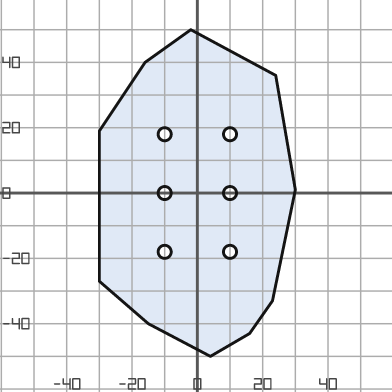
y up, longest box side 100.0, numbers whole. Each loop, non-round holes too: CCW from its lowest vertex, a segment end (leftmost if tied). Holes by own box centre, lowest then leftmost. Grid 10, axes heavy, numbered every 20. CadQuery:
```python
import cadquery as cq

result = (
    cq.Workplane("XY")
    .moveTo(4.0, -50.0)
    .lineTo(16.0, -43.0)
    .lineTo(23.0, -33.0)
    .lineTo(30.0, 1.0)
    .lineTo(24.0, 36.0)
    .lineTo(-2.0, 50.0)
    .lineTo(-16.0, 40.0)
    .lineTo(-30.0, 19.0)
    .lineTo(-30.0, -27.0)
    .lineTo(-15.0, -40.0)
    .close()
    .moveTo(-10.0, -18.0)
    .circle(2.0)
    .moveTo(10.0, -18.0)
    .circle(2.0)
    .moveTo(-10.0, 0.0)
    .circle(2.0)
    .moveTo(10.0, 0.0)
    .circle(2.0)
    .moveTo(-10.0, 18.0)
    .circle(2.0)
    .moveTo(10.0, 18.0)
    .circle(2.0)
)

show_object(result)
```